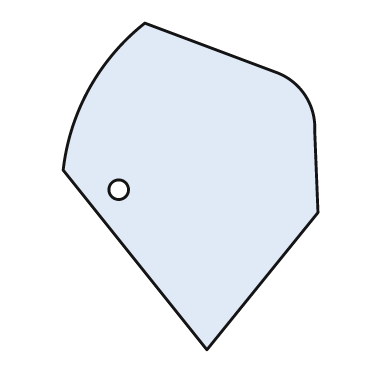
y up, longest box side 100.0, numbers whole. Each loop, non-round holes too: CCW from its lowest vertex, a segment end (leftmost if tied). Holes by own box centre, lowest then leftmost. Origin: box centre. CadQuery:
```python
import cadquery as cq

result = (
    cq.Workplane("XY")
    .moveTo(5.0, -50.0)
    .lineTo(39.0, -8.0)
    .lineTo(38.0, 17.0)
    .threePointArc((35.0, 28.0), (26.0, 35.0))
    .lineTo(-14.0, 50.0)
    .threePointArc((-31.0, 30.0), (-39.0, 5.0))
    .close()
    .moveTo(-22.0, -1.0)
    .circle(3.0)
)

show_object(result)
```